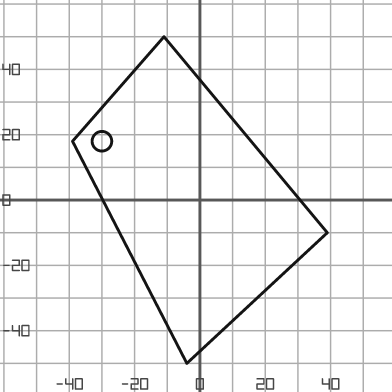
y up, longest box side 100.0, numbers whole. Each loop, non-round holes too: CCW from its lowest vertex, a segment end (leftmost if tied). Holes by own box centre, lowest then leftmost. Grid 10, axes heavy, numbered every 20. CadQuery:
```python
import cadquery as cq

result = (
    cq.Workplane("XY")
    .moveTo(-4.0, -50.0)
    .lineTo(39.0, -10.0)
    .lineTo(-11.0, 50.0)
    .lineTo(-39.0, 18.0)
    .close()
    .moveTo(-30.0, 18.0)
    .circle(3.0)
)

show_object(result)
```